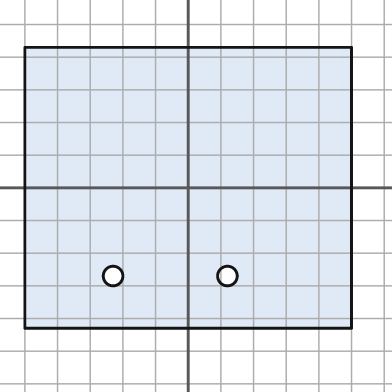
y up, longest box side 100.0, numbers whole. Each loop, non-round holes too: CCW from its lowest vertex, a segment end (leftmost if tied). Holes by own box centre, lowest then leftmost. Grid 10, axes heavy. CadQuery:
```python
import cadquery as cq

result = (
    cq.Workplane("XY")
    .moveTo(-50.0, -43.0)
    .lineTo(50.0, -43.0)
    .lineTo(50.0, 43.0)
    .lineTo(-50.0, 43.0)
    .close()
    .moveTo(-23.0, -27.0)
    .circle(3.0)
    .moveTo(12.0, -27.0)
    .circle(3.0)
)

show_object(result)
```